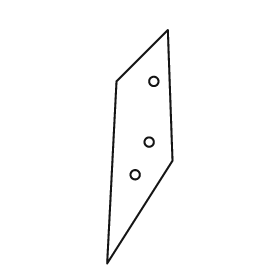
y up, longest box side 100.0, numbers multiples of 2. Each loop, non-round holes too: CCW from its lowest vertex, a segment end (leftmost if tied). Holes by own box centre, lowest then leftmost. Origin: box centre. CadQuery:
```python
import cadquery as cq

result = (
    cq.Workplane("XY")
    .moveTo(-14.0, -50.0)
    .lineTo(14.0, -6.0)
    .lineTo(12.0, 50.0)
    .lineTo(-10.0, 28.0)
    .close()
    .moveTo(-2.0, -12.0)
    .circle(2.0)
    .moveTo(4.0, 2.0)
    .circle(2.0)
    .moveTo(6.0, 28.0)
    .circle(2.0)
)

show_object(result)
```